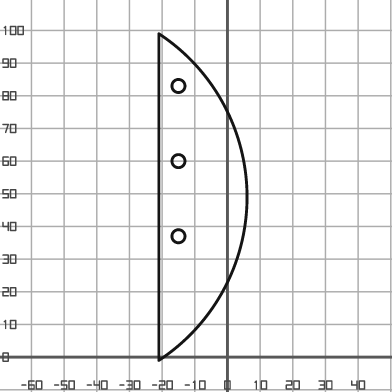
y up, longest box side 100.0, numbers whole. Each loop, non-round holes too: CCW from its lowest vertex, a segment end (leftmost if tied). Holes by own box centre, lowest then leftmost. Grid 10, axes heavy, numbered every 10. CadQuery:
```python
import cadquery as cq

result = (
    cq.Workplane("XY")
    .moveTo(-21.0, -1.0)
    .threePointArc((6.0, 49.0), (-21.0, 99.0))
    .close()
    .moveTo(-15.0, 37.0)
    .circle(2.0)
    .moveTo(-15.0, 60.0)
    .circle(2.0)
    .moveTo(-15.0, 83.0)
    .circle(2.0)
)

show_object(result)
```